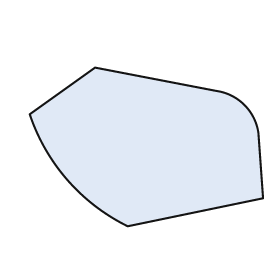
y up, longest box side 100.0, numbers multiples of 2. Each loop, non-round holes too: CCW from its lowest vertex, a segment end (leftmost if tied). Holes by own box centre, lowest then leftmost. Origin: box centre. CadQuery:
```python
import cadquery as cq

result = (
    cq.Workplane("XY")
    .moveTo(-8.0, -34.0)
    .lineTo(50.0, -22.0)
    .lineTo(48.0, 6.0)
    .threePointArc((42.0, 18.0), (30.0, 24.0))
    .lineTo(-22.0, 34.0)
    .lineTo(-50.0, 14.0)
    .threePointArc((-34.0, -14.0), (-8.0, -34.0))
    .close()
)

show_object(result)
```